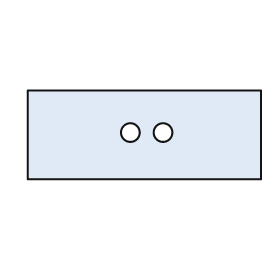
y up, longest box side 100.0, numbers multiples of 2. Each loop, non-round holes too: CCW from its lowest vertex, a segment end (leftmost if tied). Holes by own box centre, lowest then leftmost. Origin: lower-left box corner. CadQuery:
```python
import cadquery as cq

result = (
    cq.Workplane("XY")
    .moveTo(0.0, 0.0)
    .lineTo(100.0, 0.0)
    .lineTo(100.0, 38.0)
    .lineTo(0.0, 38.0)
    .close()
    .moveTo(44.0, 20.0)
    .circle(4.0)
    .moveTo(58.0, 20.0)
    .circle(4.0)
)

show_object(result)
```